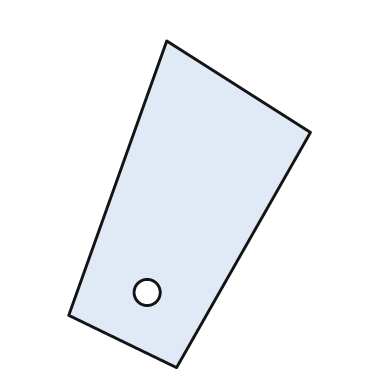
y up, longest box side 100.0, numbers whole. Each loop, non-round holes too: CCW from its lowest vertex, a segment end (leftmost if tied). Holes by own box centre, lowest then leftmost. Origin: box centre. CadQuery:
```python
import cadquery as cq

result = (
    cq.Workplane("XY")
    .moveTo(-4.0, -50.0)
    .lineTo(37.0, 22.0)
    .lineTo(-7.0, 50.0)
    .lineTo(-37.0, -34.0)
    .close()
    .moveTo(-13.0, -27.0)
    .circle(4.0)
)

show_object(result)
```